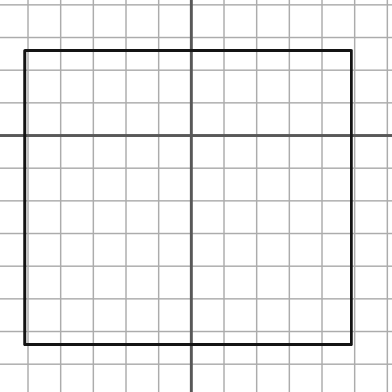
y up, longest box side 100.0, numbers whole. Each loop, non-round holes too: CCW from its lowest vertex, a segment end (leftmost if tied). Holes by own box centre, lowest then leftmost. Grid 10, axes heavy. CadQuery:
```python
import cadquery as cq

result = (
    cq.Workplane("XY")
    .moveTo(-51.0, -64.0)
    .lineTo(49.0, -64.0)
    .lineTo(49.0, 26.0)
    .lineTo(-51.0, 26.0)
    .close()
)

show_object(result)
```